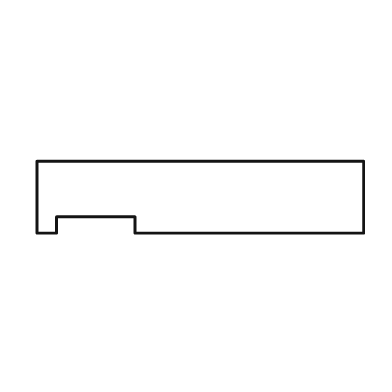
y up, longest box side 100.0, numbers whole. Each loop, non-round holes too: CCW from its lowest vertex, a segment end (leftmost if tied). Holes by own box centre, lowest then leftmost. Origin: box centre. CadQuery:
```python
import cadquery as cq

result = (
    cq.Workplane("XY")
    .moveTo(-50.0, -11.0)
    .lineTo(-44.0, -11.0)
    .lineTo(-44.0, -6.0)
    .lineTo(-20.0, -6.0)
    .lineTo(-20.0, -11.0)
    .lineTo(50.0, -11.0)
    .lineTo(50.0, 11.0)
    .lineTo(-50.0, 11.0)
    .close()
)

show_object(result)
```